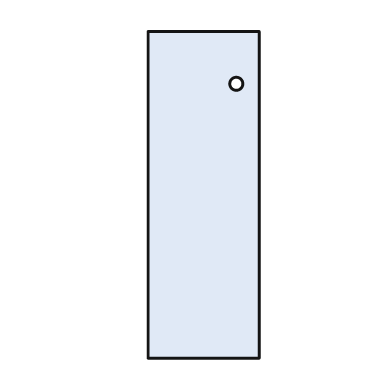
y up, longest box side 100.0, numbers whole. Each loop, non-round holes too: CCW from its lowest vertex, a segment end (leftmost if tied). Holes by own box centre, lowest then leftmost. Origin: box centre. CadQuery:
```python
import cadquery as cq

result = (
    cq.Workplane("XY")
    .moveTo(-17.0, -50.0)
    .lineTo(17.0, -50.0)
    .lineTo(17.0, 50.0)
    .lineTo(-17.0, 50.0)
    .close()
    .moveTo(10.0, 34.0)
    .circle(2.0)
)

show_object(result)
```